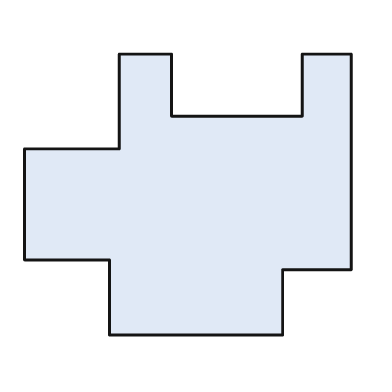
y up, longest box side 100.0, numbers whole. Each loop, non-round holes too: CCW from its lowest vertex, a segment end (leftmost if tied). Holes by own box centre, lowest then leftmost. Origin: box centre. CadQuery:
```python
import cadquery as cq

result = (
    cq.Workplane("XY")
    .moveTo(-24.0, -43.0)
    .lineTo(29.0, -43.0)
    .lineTo(29.0, -23.0)
    .lineTo(50.0, -23.0)
    .lineTo(50.0, 43.0)
    .lineTo(35.0, 43.0)
    .lineTo(35.0, 24.0)
    .lineTo(-5.0, 24.0)
    .lineTo(-5.0, 43.0)
    .lineTo(-21.0, 43.0)
    .lineTo(-21.0, 14.0)
    .lineTo(-50.0, 14.0)
    .lineTo(-50.0, -20.0)
    .lineTo(-24.0, -20.0)
    .close()
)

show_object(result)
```